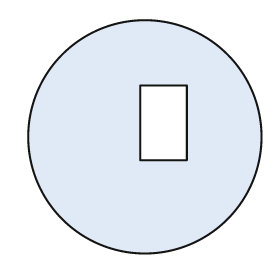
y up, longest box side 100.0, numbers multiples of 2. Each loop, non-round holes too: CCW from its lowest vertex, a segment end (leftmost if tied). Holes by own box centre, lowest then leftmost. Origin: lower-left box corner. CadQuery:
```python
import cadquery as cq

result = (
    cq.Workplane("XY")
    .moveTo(50.0, 50.0)
    .circle(50.0)
    .moveTo(48.0, 40.0)
    .lineTo(68.0, 40.0)
    .lineTo(68.0, 72.0)
    .lineTo(48.0, 72.0)
    .close()
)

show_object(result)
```